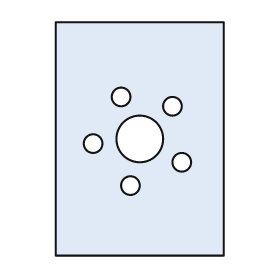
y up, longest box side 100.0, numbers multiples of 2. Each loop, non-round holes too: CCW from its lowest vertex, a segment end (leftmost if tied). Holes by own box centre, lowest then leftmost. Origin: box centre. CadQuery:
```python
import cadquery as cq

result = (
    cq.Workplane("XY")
    .moveTo(-36.0, -50.0)
    .lineTo(36.0, -50.0)
    .lineTo(36.0, 50.0)
    .lineTo(-36.0, 50.0)
    .close()
    .moveTo(-4.0, -20.0)
    .circle(4.0)
    .moveTo(18.0, -10.0)
    .circle(4.0)
    .moveTo(-20.0, -2.0)
    .circle(4.0)
    .moveTo(0.0, 0.0)
    .circle(10.0)
    .moveTo(14.0, 14.0)
    .circle(4.0)
    .moveTo(-8.0, 18.0)
    .circle(4.0)
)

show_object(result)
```